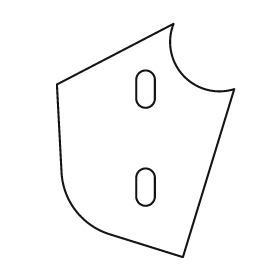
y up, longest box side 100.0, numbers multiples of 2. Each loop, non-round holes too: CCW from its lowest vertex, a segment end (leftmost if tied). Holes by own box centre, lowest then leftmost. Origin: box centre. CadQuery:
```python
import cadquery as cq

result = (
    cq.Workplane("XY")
    .moveTo(16.0, -50.0)
    .lineTo(38.0, 22.0)
    .threePointArc((16.0, 28.0), (12.0, 50.0))
    .lineTo(-38.0, 24.0)
    .lineTo(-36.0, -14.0)
    .threePointArc((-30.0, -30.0), (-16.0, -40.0))
    .close()
    .moveTo(-4.0, -24.0)
    .threePointArc((0.0, -28.0), (4.0, -24.0))
    .lineTo(4.0, -16.0)
    .threePointArc((0.0, -12.0), (-4.0, -16.0))
    .close()
    .moveTo(-4.0, 18.0)
    .threePointArc((0.0, 14.0), (4.0, 18.0))
    .lineTo(4.0, 26.0)
    .threePointArc((0.0, 30.0), (-4.0, 26.0))
    .close()
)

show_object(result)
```